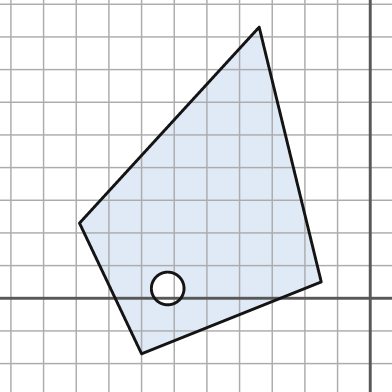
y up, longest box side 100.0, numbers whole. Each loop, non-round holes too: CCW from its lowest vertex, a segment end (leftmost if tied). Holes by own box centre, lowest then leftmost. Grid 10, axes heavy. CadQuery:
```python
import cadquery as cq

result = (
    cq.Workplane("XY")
    .moveTo(-70.0, -17.0)
    .lineTo(-15.0, 5.0)
    .lineTo(-34.0, 83.0)
    .lineTo(-89.0, 23.0)
    .close()
    .moveTo(-62.0, 3.0)
    .circle(5.0)
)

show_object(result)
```